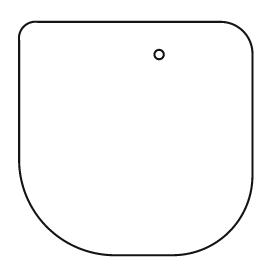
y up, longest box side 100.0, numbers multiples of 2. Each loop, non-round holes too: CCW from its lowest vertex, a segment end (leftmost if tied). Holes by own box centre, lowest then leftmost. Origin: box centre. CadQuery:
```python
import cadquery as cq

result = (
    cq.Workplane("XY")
    .moveTo(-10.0, -50.0)
    .lineTo(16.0, -50.0)
    .threePointArc((40.0, -40.0), (50.0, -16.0))
    .lineTo(50.0, 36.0)
    .threePointArc((46.0, 46.0), (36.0, 50.0))
    .lineTo(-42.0, 50.0)
    .threePointArc((-48.0, 48.0), (-50.0, 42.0))
    .lineTo(-50.0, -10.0)
    .threePointArc((-38.0, -38.0), (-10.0, -50.0))
    .close()
    .moveTo(10.0, 36.0)
    .circle(2.0)
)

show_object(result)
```